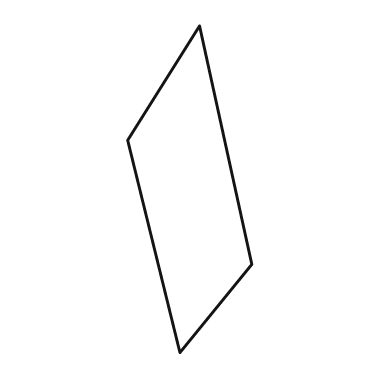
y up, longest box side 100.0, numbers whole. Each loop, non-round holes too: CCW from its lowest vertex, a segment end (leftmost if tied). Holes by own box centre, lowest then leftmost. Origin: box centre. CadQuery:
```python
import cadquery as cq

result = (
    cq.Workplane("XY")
    .moveTo(-3.0, -50.0)
    .lineTo(19.0, -23.0)
    .lineTo(3.0, 50.0)
    .lineTo(-19.0, 15.0)
    .close()
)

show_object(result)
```